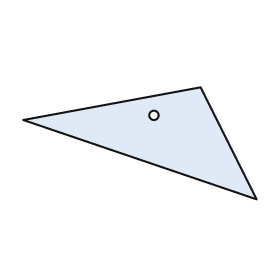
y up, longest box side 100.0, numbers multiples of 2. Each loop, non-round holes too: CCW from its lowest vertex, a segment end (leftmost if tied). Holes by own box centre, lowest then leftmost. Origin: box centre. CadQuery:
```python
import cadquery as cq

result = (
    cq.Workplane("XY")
    .moveTo(50.0, -24.0)
    .lineTo(26.0, 24.0)
    .lineTo(-50.0, 10.0)
    .close()
    .moveTo(6.0, 12.0)
    .circle(2.0)
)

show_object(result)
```